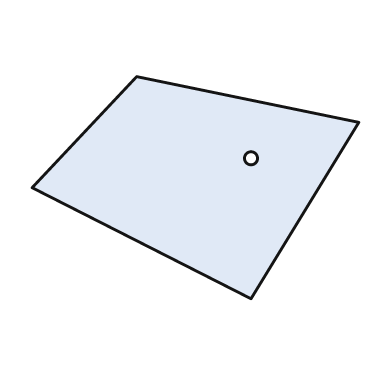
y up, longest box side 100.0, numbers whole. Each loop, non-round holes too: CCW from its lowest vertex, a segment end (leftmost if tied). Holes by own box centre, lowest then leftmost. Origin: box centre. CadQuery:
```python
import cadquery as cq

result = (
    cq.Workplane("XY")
    .moveTo(17.0, -34.0)
    .lineTo(50.0, 20.0)
    .lineTo(-18.0, 34.0)
    .lineTo(-50.0, 0.0)
    .close()
    .moveTo(17.0, 9.0)
    .circle(2.0)
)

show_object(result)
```